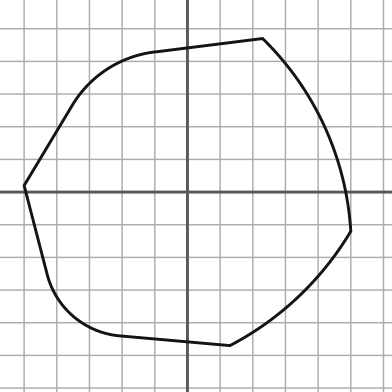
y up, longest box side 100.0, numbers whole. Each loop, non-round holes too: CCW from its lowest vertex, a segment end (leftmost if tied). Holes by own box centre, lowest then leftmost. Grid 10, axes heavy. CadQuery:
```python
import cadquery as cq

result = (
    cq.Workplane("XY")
    .moveTo(13.0, -47.0)
    .threePointArc((34.0, -32.0), (50.0, -12.0))
    .threePointArc((42.0, 20.0), (23.0, 47.0))
    .lineTo(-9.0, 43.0)
    .threePointArc((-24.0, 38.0), (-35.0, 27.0))
    .lineTo(-50.0, 2.0)
    .lineTo(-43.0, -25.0)
    .threePointArc((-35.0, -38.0), (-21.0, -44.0))
    .close()
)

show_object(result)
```